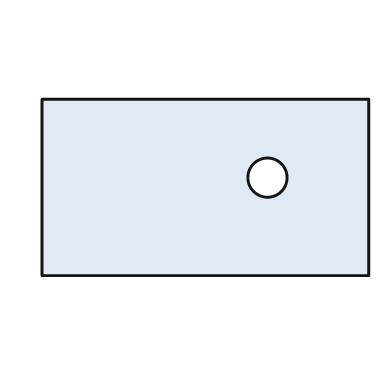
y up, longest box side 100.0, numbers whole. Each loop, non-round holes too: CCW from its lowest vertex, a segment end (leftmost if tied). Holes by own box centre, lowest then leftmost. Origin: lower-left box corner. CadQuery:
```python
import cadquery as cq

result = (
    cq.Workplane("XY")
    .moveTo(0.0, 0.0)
    .lineTo(100.0, 0.0)
    .lineTo(100.0, 54.0)
    .lineTo(0.0, 54.0)
    .close()
    .moveTo(69.0, 30.0)
    .circle(6.0)
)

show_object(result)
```